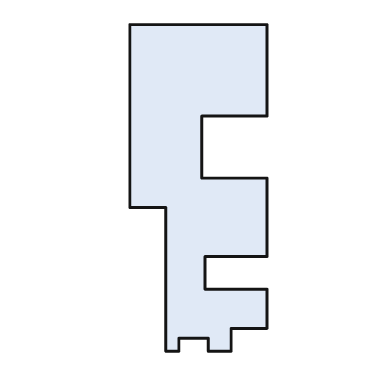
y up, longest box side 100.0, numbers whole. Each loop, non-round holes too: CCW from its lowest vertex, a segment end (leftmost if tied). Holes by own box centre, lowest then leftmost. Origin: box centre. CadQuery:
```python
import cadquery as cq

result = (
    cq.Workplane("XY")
    .moveTo(-10.0, -50.0)
    .lineTo(-6.0, -50.0)
    .lineTo(-6.0, -46.0)
    .lineTo(3.0, -46.0)
    .lineTo(3.0, -50.0)
    .lineTo(10.0, -50.0)
    .lineTo(10.0, -43.0)
    .lineTo(21.0, -43.0)
    .lineTo(21.0, -31.0)
    .lineTo(2.0, -31.0)
    .lineTo(2.0, -21.0)
    .lineTo(21.0, -21.0)
    .lineTo(21.0, 3.0)
    .lineTo(1.0, 3.0)
    .lineTo(1.0, 22.0)
    .lineTo(21.0, 22.0)
    .lineTo(21.0, 50.0)
    .lineTo(-21.0, 50.0)
    .lineTo(-21.0, -6.0)
    .lineTo(-10.0, -6.0)
    .close()
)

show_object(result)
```